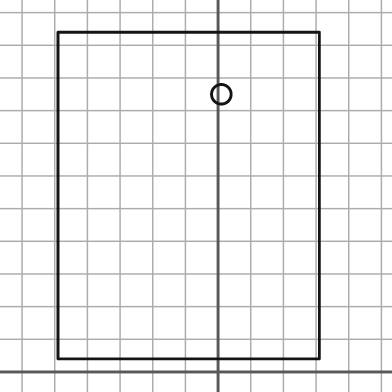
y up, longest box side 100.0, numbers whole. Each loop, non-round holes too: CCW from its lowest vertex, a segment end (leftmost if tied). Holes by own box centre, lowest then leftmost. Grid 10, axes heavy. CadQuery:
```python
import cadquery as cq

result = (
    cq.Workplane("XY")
    .moveTo(-49.0, 4.0)
    .lineTo(31.0, 4.0)
    .lineTo(31.0, 104.0)
    .lineTo(-49.0, 104.0)
    .close()
    .moveTo(1.0, 85.0)
    .circle(3.0)
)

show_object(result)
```